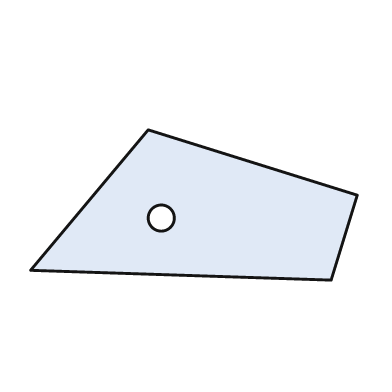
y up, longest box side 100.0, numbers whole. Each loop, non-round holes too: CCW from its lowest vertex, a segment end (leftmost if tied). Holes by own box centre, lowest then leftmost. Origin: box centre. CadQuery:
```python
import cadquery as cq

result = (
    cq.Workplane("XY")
    .moveTo(42.0, -23.0)
    .lineTo(50.0, 3.0)
    .lineTo(-14.0, 23.0)
    .lineTo(-50.0, -20.0)
    .close()
    .moveTo(-10.0, -4.0)
    .circle(4.0)
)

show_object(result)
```